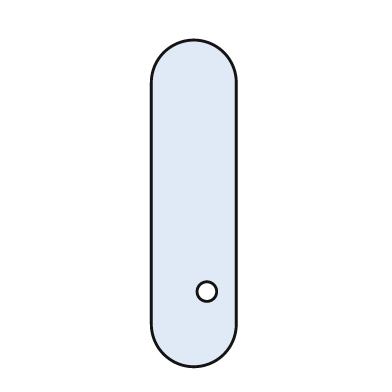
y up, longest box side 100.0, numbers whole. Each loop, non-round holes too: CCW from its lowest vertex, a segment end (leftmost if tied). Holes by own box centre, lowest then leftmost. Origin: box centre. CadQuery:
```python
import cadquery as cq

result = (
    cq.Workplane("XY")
    .moveTo(-13.0, -37.0)
    .threePointArc((0.0, -50.0), (13.0, -37.0))
    .lineTo(13.0, 37.0)
    .threePointArc((0.0, 50.0), (-13.0, 37.0))
    .close()
    .moveTo(4.0, -27.0)
    .circle(3.0)
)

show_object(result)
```